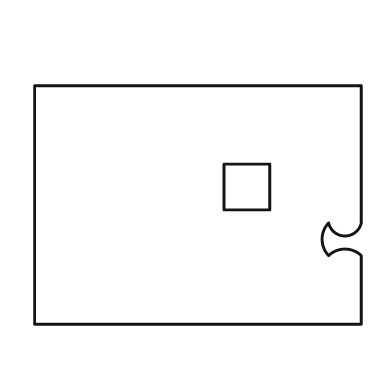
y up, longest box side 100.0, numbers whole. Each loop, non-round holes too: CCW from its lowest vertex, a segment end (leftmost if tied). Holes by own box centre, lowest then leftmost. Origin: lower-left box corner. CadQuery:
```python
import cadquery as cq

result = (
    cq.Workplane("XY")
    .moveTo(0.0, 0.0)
    .lineTo(100.0, 0.0)
    .lineTo(100.0, 21.0)
    .threePointArc((95.0, 23.0), (90.0, 21.0))
    .threePointArc((88.0, 26.0), (90.0, 31.0))
    .threePointArc((95.0, 27.0), (100.0, 31.0))
    .lineTo(100.0, 73.0)
    .lineTo(0.0, 73.0)
    .close()
    .moveTo(58.0, 35.0)
    .lineTo(72.0, 35.0)
    .lineTo(72.0, 49.0)
    .lineTo(58.0, 49.0)
    .close()
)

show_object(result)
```